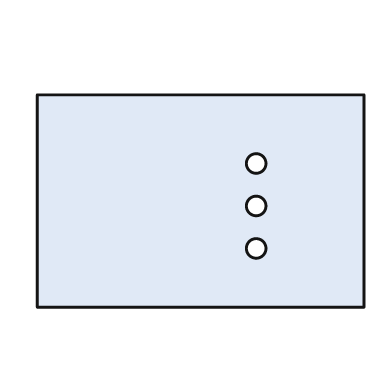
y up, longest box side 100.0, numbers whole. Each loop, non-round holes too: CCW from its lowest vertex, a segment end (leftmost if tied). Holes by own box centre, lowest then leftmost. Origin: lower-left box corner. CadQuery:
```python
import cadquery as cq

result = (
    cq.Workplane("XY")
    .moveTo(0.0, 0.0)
    .lineTo(100.0, 0.0)
    .lineTo(100.0, 65.0)
    .lineTo(0.0, 65.0)
    .close()
    .moveTo(67.0, 18.0)
    .circle(3.0)
    .moveTo(67.0, 31.0)
    .circle(3.0)
    .moveTo(67.0, 44.0)
    .circle(3.0)
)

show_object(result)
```